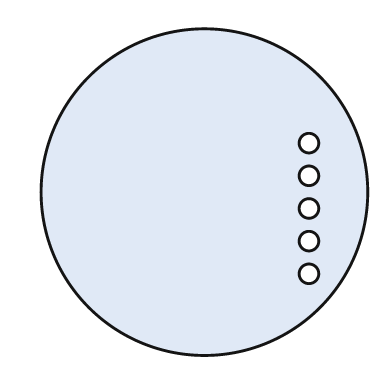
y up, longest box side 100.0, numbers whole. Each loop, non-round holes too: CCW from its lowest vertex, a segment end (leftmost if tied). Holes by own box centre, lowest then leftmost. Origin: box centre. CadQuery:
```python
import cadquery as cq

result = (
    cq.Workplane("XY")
    .moveTo(0.0, 0.0)
    .circle(50.0)
    .moveTo(32.0, -25.0)
    .circle(3.0)
    .moveTo(32.0, -15.0)
    .circle(3.0)
    .moveTo(32.0, -5.0)
    .circle(3.0)
    .moveTo(32.0, 5.0)
    .circle(3.0)
    .moveTo(32.0, 15.0)
    .circle(3.0)
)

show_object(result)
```